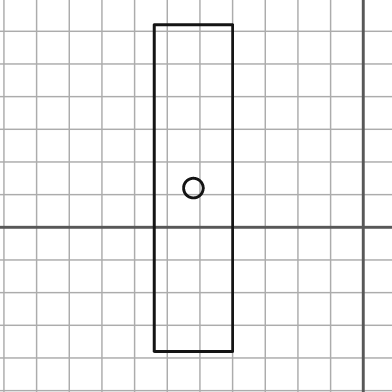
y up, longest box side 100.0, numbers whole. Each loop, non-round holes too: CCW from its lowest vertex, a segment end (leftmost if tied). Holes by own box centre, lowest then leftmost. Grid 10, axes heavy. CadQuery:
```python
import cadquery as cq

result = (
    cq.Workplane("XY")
    .moveTo(-64.0, -38.0)
    .lineTo(-40.0, -38.0)
    .lineTo(-40.0, 62.0)
    .lineTo(-64.0, 62.0)
    .close()
    .moveTo(-52.0, 12.0)
    .circle(3.0)
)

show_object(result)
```